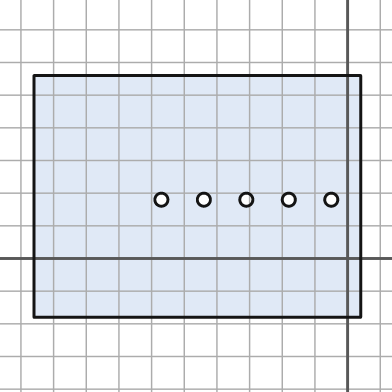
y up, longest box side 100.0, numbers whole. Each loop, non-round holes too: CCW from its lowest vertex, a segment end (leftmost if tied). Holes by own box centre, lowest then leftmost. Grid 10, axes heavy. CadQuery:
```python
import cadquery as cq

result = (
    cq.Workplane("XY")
    .moveTo(-96.0, -18.0)
    .lineTo(4.0, -18.0)
    .lineTo(4.0, 56.0)
    .lineTo(-96.0, 56.0)
    .close()
    .moveTo(-57.0, 18.0)
    .circle(2.0)
    .moveTo(-44.0, 18.0)
    .circle(2.0)
    .moveTo(-31.0, 18.0)
    .circle(2.0)
    .moveTo(-18.0, 18.0)
    .circle(2.0)
    .moveTo(-5.0, 18.0)
    .circle(2.0)
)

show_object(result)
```